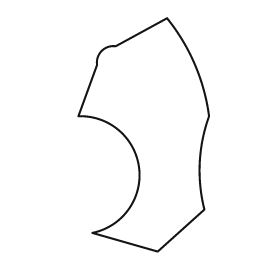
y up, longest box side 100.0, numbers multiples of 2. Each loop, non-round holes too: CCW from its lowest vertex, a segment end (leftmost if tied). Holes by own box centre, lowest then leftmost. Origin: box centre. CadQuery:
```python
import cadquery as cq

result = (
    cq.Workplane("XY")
    .moveTo(6.0, -50.0)
    .lineTo(26.0, -32.0)
    .threePointArc((24.0, -12.0), (28.0, 8.0))
    .threePointArc((22.0, 30.0), (10.0, 50.0))
    .lineTo(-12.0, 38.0)
    .threePointArc((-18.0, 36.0), (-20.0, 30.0))
    .lineTo(-28.0, 8.0)
    .threePointArc((-2.0, -14.0), (-22.0, -42.0))
    .close()
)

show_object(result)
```